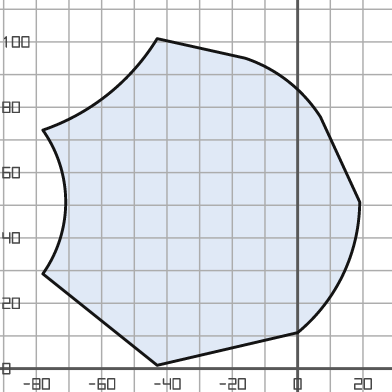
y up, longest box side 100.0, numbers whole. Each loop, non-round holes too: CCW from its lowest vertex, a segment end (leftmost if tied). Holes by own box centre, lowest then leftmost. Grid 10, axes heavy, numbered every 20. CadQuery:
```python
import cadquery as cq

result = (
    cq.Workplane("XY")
    .moveTo(-43.0, 1.0)
    .lineTo(0.0, 11.0)
    .threePointArc((14.0, 29.0), (19.0, 51.0))
    .lineTo(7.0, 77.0)
    .threePointArc((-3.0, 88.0), (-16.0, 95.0))
    .lineTo(-43.0, 101.0)
    .threePointArc((-58.0, 84.0), (-78.0, 73.0))
    .threePointArc((-71.0, 51.0), (-78.0, 29.0))
    .close()
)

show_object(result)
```